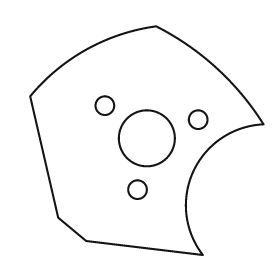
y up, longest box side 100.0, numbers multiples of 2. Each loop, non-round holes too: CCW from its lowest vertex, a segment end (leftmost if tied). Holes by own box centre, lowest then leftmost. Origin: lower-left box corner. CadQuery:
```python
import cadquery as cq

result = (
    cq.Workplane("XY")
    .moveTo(74.0, 0.0)
    .threePointArc((70.0, 36.0), (100.0, 56.0))
    .threePointArc((80.0, 80.0), (54.0, 98.0))
    .threePointArc((24.0, 88.0), (0.0, 68.0))
    .lineTo(12.0, 16.0)
    .lineTo(24.0, 6.0)
    .close()
    .moveTo(46.0, 28.0)
    .circle(4.0)
    .moveTo(50.0, 50.0)
    .circle(12.0)
    .moveTo(72.0, 58.0)
    .circle(4.0)
    .moveTo(32.0, 64.0)
    .circle(4.0)
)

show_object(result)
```